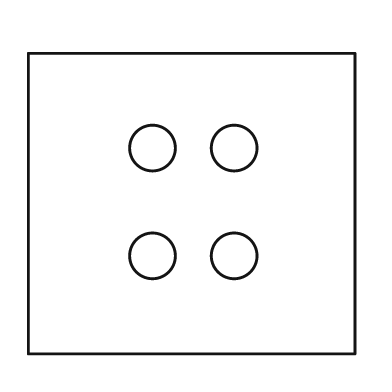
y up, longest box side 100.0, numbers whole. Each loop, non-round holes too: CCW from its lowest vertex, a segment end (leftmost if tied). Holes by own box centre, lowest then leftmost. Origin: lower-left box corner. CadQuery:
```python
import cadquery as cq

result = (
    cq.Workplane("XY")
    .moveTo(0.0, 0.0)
    .lineTo(100.0, 0.0)
    .lineTo(100.0, 92.0)
    .lineTo(0.0, 92.0)
    .close()
    .moveTo(38.0, 30.0)
    .circle(7.0)
    .moveTo(63.0, 30.0)
    .circle(7.0)
    .moveTo(38.0, 63.0)
    .circle(7.0)
    .moveTo(63.0, 63.0)
    .circle(7.0)
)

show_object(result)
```